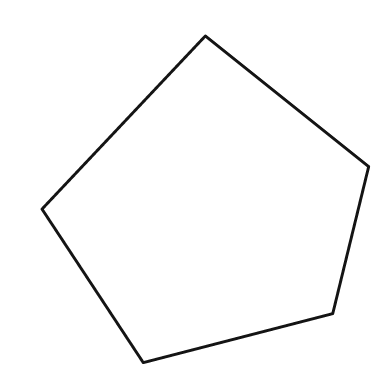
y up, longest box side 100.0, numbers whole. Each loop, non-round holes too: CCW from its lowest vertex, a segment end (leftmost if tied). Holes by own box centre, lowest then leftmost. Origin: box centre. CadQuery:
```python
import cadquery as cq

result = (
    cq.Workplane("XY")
    .moveTo(-19.0, -50.0)
    .lineTo(39.0, -35.0)
    .lineTo(50.0, 10.0)
    .lineTo(0.0, 50.0)
    .lineTo(-50.0, -3.0)
    .close()
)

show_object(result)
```